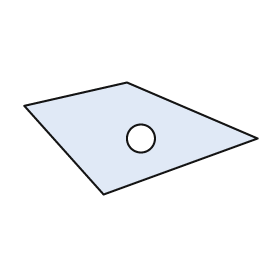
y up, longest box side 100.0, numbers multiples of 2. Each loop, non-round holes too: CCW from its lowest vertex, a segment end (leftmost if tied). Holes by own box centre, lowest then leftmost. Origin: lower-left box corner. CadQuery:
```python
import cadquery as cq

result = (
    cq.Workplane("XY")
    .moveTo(34.0, 0.0)
    .lineTo(100.0, 24.0)
    .lineTo(44.0, 48.0)
    .lineTo(0.0, 38.0)
    .close()
    .moveTo(50.0, 24.0)
    .circle(6.0)
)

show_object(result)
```